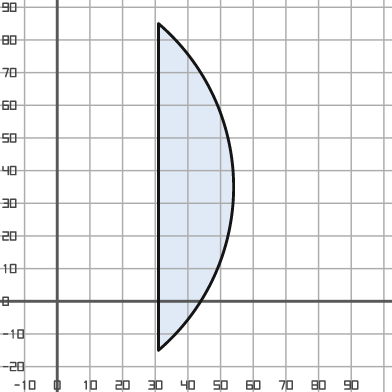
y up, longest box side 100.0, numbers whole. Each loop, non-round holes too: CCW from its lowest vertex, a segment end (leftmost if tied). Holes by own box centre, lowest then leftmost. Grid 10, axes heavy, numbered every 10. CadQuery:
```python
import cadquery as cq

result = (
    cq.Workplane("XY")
    .moveTo(31.0, -15.0)
    .threePointArc((54.0, 35.0), (31.0, 85.0))
    .close()
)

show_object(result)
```